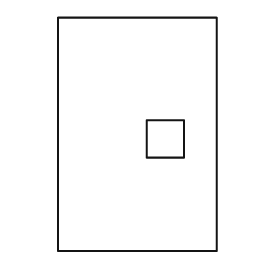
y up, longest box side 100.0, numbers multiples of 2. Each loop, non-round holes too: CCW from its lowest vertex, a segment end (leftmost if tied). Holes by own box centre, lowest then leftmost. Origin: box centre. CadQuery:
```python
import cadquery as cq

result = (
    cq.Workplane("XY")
    .moveTo(-34.0, -50.0)
    .lineTo(34.0, -50.0)
    .lineTo(34.0, 50.0)
    .lineTo(-34.0, 50.0)
    .close()
    .moveTo(4.0, -10.0)
    .lineTo(20.0, -10.0)
    .lineTo(20.0, 6.0)
    .lineTo(4.0, 6.0)
    .close()
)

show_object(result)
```